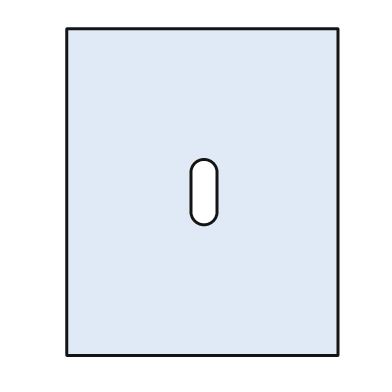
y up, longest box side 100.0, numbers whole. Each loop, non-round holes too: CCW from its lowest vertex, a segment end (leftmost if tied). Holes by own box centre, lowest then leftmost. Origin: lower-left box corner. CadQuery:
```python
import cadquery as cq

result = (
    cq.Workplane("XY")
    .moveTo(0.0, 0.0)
    .lineTo(83.0, 0.0)
    .lineTo(83.0, 100.0)
    .lineTo(0.0, 100.0)
    .close()
    .moveTo(38.0, 44.0)
    .threePointArc((42.0, 40.0), (46.0, 44.0))
    .lineTo(46.0, 56.0)
    .threePointArc((42.0, 60.0), (38.0, 56.0))
    .close()
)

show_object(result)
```